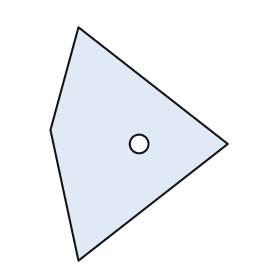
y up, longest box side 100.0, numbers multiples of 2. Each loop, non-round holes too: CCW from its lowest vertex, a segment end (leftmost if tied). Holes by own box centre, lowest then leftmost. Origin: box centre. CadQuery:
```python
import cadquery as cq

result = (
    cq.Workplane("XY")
    .moveTo(-26.0, -50.0)
    .lineTo(38.0, 0.0)
    .lineTo(-26.0, 50.0)
    .lineTo(-38.0, 6.0)
    .close()
    .moveTo(0.0, 0.0)
    .circle(4.0)
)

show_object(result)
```